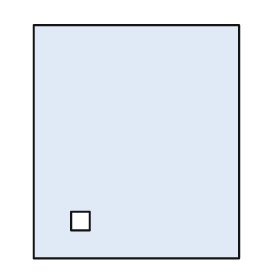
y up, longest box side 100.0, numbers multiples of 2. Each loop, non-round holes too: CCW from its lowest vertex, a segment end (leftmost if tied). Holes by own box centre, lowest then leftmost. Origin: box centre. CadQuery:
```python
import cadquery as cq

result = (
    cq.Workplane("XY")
    .moveTo(-44.0, -50.0)
    .lineTo(44.0, -50.0)
    .lineTo(44.0, 50.0)
    .lineTo(-44.0, 50.0)
    .close()
    .moveTo(-28.0, -38.0)
    .lineTo(-20.0, -38.0)
    .lineTo(-20.0, -30.0)
    .lineTo(-28.0, -30.0)
    .close()
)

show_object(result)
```